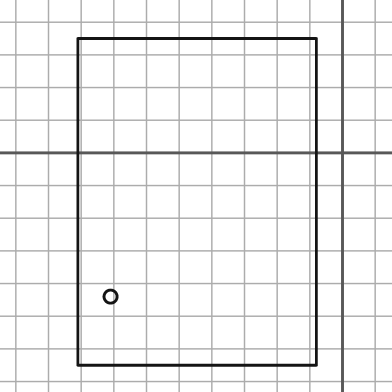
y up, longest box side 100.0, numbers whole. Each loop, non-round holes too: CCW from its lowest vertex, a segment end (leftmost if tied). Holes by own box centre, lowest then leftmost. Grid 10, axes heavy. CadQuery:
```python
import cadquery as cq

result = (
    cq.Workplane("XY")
    .moveTo(-81.0, -65.0)
    .lineTo(-8.0, -65.0)
    .lineTo(-8.0, 35.0)
    .lineTo(-81.0, 35.0)
    .close()
    .moveTo(-71.0, -44.0)
    .circle(2.0)
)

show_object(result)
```